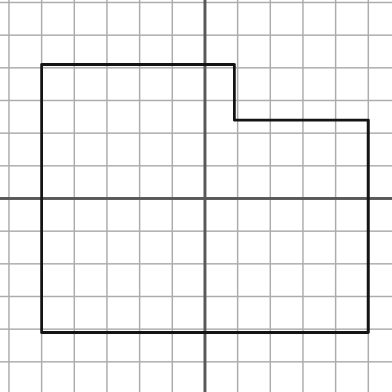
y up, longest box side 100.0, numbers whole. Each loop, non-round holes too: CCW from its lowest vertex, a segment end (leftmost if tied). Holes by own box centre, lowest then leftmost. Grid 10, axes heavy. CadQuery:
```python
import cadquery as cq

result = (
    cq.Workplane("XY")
    .moveTo(-50.0, -41.0)
    .lineTo(50.0, -41.0)
    .lineTo(50.0, 24.0)
    .lineTo(9.0, 24.0)
    .lineTo(9.0, 41.0)
    .lineTo(-50.0, 41.0)
    .close()
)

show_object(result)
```